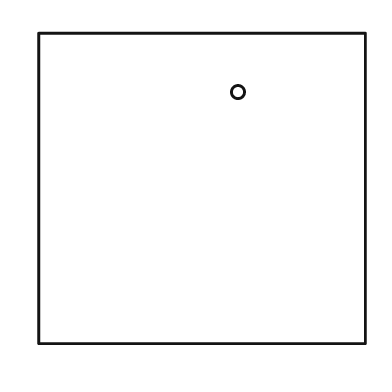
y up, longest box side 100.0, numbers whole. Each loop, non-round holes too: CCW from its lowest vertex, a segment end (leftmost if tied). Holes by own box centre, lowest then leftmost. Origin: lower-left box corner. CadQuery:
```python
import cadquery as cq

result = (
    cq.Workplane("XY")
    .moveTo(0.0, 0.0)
    .lineTo(100.0, 0.0)
    .lineTo(100.0, 95.0)
    .lineTo(0.0, 95.0)
    .close()
    .moveTo(61.0, 77.0)
    .circle(2.0)
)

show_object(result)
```